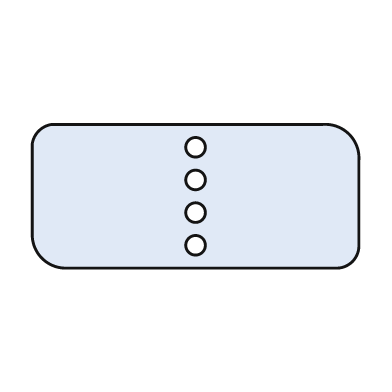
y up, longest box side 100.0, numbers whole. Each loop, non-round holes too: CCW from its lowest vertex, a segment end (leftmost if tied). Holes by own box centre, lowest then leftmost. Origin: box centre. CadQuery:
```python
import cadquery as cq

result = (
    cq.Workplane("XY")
    .moveTo(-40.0, -22.0)
    .lineTo(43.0, -22.0)
    .threePointArc((48.0, -20.0), (50.0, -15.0))
    .lineTo(50.0, 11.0)
    .threePointArc((47.0, 19.0), (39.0, 22.0))
    .lineTo(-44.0, 22.0)
    .threePointArc((-48.0, 20.0), (-50.0, 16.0))
    .lineTo(-50.0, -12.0)
    .threePointArc((-47.0, -19.0), (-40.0, -22.0))
    .close()
    .moveTo(0.0, -15.0)
    .circle(3.0)
    .moveTo(0.0, -5.0)
    .circle(3.0)
    .moveTo(0.0, 5.0)
    .circle(3.0)
    .moveTo(0.0, 15.0)
    .circle(3.0)
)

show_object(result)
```